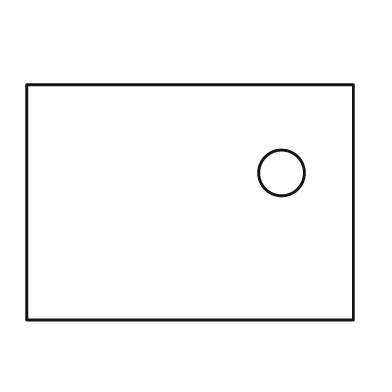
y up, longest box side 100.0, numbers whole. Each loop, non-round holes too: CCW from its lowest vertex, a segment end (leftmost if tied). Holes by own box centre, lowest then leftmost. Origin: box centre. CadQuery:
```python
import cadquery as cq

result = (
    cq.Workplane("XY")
    .moveTo(-50.0, -36.0)
    .lineTo(50.0, -36.0)
    .lineTo(50.0, 36.0)
    .lineTo(-50.0, 36.0)
    .close()
    .moveTo(28.0, 9.0)
    .circle(7.0)
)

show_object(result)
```